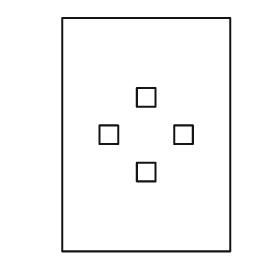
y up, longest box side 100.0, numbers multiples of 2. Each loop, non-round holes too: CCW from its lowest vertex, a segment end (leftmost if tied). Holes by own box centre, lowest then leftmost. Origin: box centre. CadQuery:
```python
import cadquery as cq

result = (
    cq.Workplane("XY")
    .moveTo(-36.0, -50.0)
    .lineTo(36.0, -50.0)
    .lineTo(36.0, 50.0)
    .lineTo(-36.0, 50.0)
    .close()
    .moveTo(-4.0, -20.0)
    .lineTo(4.0, -20.0)
    .lineTo(4.0, -12.0)
    .lineTo(-4.0, -12.0)
    .close()
    .moveTo(-20.0, -4.0)
    .lineTo(-12.0, -4.0)
    .lineTo(-12.0, 4.0)
    .lineTo(-20.0, 4.0)
    .close()
    .moveTo(12.0, -4.0)
    .lineTo(20.0, -4.0)
    .lineTo(20.0, 4.0)
    .lineTo(12.0, 4.0)
    .close()
    .moveTo(-4.0, 12.0)
    .lineTo(4.0, 12.0)
    .lineTo(4.0, 20.0)
    .lineTo(-4.0, 20.0)
    .close()
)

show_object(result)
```